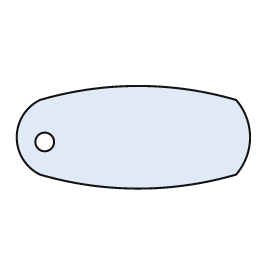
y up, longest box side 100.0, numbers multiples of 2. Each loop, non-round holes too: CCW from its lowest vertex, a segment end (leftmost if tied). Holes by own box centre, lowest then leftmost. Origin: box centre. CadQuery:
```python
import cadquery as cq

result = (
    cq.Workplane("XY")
    .moveTo(-40.0, -16.0)
    .threePointArc((2.0, -22.0), (44.0, -16.0))
    .threePointArc((50.0, 0.0), (44.0, 16.0))
    .threePointArc((2.0, 22.0), (-40.0, 16.0))
    .threePointArc((-50.0, 0.0), (-40.0, -16.0))
    .close()
    .moveTo(-38.0, -2.0)
    .circle(4.0)
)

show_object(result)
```